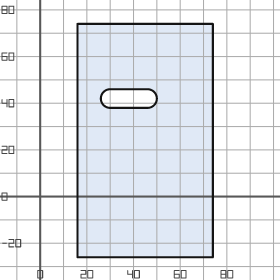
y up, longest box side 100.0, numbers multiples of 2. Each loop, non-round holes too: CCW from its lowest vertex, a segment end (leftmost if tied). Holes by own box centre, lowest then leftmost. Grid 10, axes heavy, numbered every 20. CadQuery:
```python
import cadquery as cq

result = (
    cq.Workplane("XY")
    .moveTo(16.0, -26.0)
    .lineTo(74.0, -26.0)
    .lineTo(74.0, 74.0)
    .lineTo(16.0, 74.0)
    .close()
    .moveTo(30.0, 38.0)
    .lineTo(46.0, 38.0)
    .threePointArc((50.0, 42.0), (46.0, 46.0))
    .lineTo(30.0, 46.0)
    .threePointArc((26.0, 42.0), (30.0, 38.0))
    .close()
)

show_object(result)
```